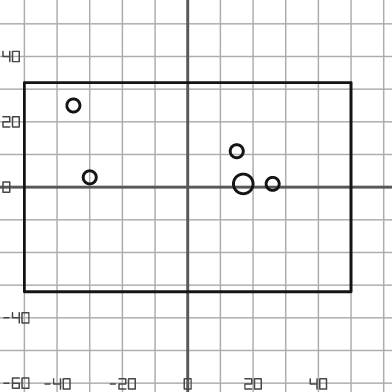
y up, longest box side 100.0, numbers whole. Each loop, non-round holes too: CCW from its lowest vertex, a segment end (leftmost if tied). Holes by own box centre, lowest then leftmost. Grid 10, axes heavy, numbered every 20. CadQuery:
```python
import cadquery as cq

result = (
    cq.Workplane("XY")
    .moveTo(-50.0, -32.0)
    .lineTo(50.0, -32.0)
    .lineTo(50.0, 32.0)
    .lineTo(-50.0, 32.0)
    .close()
    .moveTo(17.0, 1.0)
    .circle(3.0)
    .moveTo(26.0, 1.0)
    .circle(2.0)
    .moveTo(-30.0, 3.0)
    .circle(2.0)
    .moveTo(15.0, 11.0)
    .circle(2.0)
    .moveTo(-35.0, 25.0)
    .circle(2.0)
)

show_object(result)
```